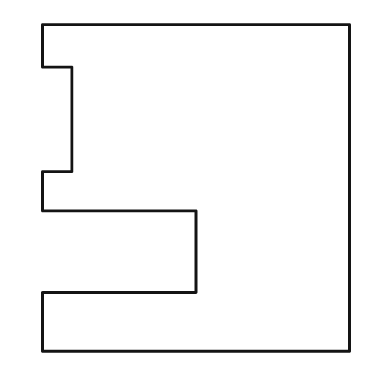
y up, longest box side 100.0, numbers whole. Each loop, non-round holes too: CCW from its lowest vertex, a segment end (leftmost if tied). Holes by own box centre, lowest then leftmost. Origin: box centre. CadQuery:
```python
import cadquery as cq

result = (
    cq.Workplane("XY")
    .moveTo(-47.0, -50.0)
    .lineTo(47.0, -50.0)
    .lineTo(47.0, 50.0)
    .lineTo(-47.0, 50.0)
    .lineTo(-47.0, 37.0)
    .lineTo(-38.0, 37.0)
    .lineTo(-38.0, 5.0)
    .lineTo(-47.0, 5.0)
    .lineTo(-47.0, -7.0)
    .lineTo(0.0, -7.0)
    .lineTo(0.0, -32.0)
    .lineTo(-47.0, -32.0)
    .close()
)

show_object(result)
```